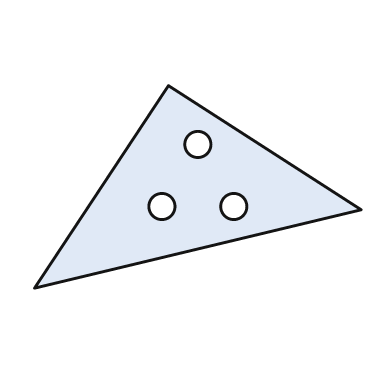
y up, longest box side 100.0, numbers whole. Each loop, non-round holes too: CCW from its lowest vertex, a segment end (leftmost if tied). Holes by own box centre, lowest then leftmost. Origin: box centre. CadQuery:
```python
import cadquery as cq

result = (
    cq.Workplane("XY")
    .moveTo(-50.0, -31.0)
    .lineTo(50.0, -7.0)
    .lineTo(-9.0, 31.0)
    .close()
    .moveTo(-11.0, -6.0)
    .circle(4.0)
    .moveTo(11.0, -6.0)
    .circle(4.0)
    .moveTo(0.0, 13.0)
    .circle(4.0)
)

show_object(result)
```